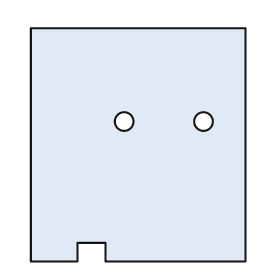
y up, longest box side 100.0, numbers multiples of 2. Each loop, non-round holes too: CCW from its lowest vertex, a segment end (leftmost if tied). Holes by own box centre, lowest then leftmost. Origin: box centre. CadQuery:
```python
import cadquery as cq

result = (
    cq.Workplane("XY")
    .moveTo(-46.0, -50.0)
    .lineTo(-26.0, -50.0)
    .lineTo(-26.0, -42.0)
    .lineTo(-14.0, -42.0)
    .lineTo(-14.0, -50.0)
    .lineTo(46.0, -50.0)
    .lineTo(46.0, 50.0)
    .lineTo(-46.0, 50.0)
    .close()
    .moveTo(-6.0, 10.0)
    .circle(4.0)
    .moveTo(28.0, 10.0)
    .circle(4.0)
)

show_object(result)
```